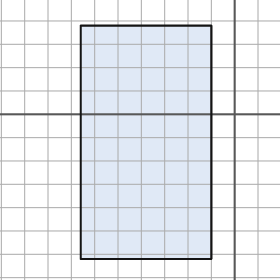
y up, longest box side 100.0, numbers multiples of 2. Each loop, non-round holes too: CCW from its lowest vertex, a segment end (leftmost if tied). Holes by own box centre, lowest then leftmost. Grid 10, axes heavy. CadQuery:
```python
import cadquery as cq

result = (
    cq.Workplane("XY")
    .moveTo(-66.0, -62.0)
    .lineTo(-10.0, -62.0)
    .lineTo(-10.0, 38.0)
    .lineTo(-66.0, 38.0)
    .close()
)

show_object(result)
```